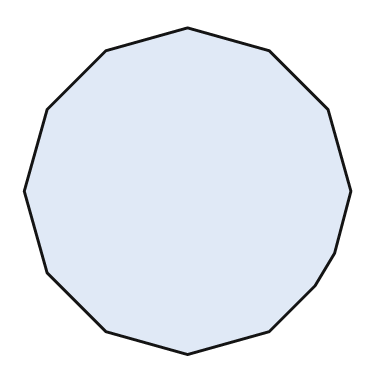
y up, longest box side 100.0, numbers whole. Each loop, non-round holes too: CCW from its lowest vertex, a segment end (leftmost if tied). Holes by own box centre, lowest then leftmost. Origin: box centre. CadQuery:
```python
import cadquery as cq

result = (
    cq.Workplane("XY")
    .moveTo(0.0, -50.0)
    .lineTo(25.0, -43.0)
    .lineTo(39.0, -29.0)
    .lineTo(45.0, -19.0)
    .lineTo(50.0, 0.0)
    .lineTo(43.0, 25.0)
    .lineTo(25.0, 43.0)
    .lineTo(0.0, 50.0)
    .lineTo(-25.0, 43.0)
    .lineTo(-43.0, 25.0)
    .lineTo(-50.0, 0.0)
    .lineTo(-43.0, -25.0)
    .lineTo(-25.0, -43.0)
    .close()
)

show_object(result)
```